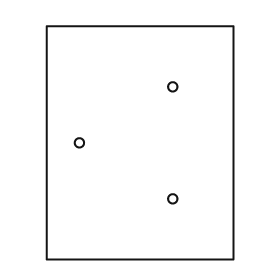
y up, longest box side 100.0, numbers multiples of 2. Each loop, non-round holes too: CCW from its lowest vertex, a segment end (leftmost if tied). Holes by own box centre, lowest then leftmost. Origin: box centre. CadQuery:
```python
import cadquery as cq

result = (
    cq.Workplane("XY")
    .moveTo(-40.0, -50.0)
    .lineTo(40.0, -50.0)
    .lineTo(40.0, 50.0)
    .lineTo(-40.0, 50.0)
    .close()
    .moveTo(14.0, -24.0)
    .circle(2.0)
    .moveTo(-26.0, 0.0)
    .circle(2.0)
    .moveTo(14.0, 24.0)
    .circle(2.0)
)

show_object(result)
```